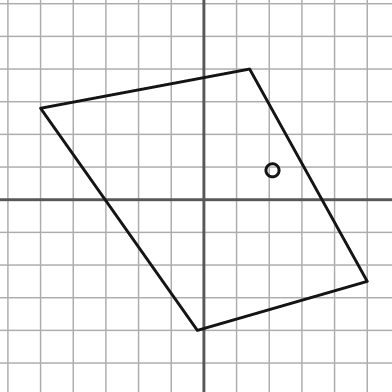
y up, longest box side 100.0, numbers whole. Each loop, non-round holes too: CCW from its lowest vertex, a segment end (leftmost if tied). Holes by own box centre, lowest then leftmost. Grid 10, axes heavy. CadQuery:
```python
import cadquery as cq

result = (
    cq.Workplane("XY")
    .moveTo(-2.0, -40.0)
    .lineTo(50.0, -25.0)
    .lineTo(14.0, 40.0)
    .lineTo(-50.0, 28.0)
    .close()
    .moveTo(21.0, 9.0)
    .circle(2.0)
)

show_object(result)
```